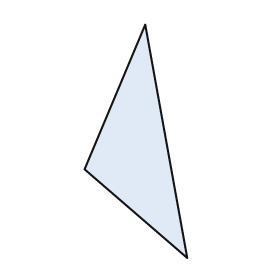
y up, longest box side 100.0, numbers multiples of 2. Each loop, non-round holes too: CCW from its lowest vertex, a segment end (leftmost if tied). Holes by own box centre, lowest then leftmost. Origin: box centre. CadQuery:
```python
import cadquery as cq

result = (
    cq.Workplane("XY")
    .moveTo(22.0, -50.0)
    .lineTo(4.0, 50.0)
    .lineTo(-22.0, -12.0)
    .close()
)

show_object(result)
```